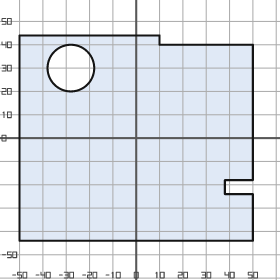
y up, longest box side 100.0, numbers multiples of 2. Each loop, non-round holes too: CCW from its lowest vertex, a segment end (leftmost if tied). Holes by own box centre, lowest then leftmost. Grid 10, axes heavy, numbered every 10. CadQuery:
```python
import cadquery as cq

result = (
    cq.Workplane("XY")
    .moveTo(-50.0, -44.0)
    .lineTo(50.0, -44.0)
    .lineTo(50.0, -24.0)
    .lineTo(38.0, -24.0)
    .lineTo(38.0, -18.0)
    .lineTo(50.0, -18.0)
    .lineTo(50.0, 40.0)
    .lineTo(10.0, 40.0)
    .lineTo(10.0, 44.0)
    .lineTo(-50.0, 44.0)
    .close()
    .moveTo(-28.0, 30.0)
    .circle(10.0)
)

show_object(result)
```